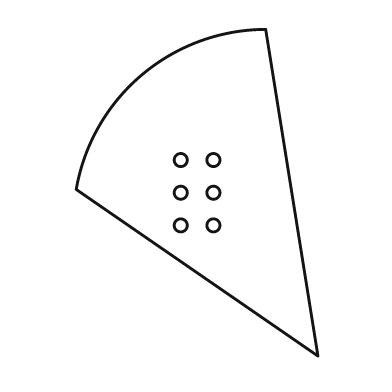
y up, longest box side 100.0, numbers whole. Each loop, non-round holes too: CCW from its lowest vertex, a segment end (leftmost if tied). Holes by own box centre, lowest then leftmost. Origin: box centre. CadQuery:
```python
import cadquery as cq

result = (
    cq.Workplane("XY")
    .moveTo(37.0, -50.0)
    .lineTo(21.0, 50.0)
    .threePointArc((-17.0, 36.0), (-37.0, 1.0))
    .close()
    .moveTo(-5.0, -10.0)
    .circle(2.0)
    .moveTo(5.0, -10.0)
    .circle(2.0)
    .moveTo(-5.0, 0.0)
    .circle(2.0)
    .moveTo(5.0, 0.0)
    .circle(2.0)
    .moveTo(-5.0, 10.0)
    .circle(2.0)
    .moveTo(5.0, 10.0)
    .circle(2.0)
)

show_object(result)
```